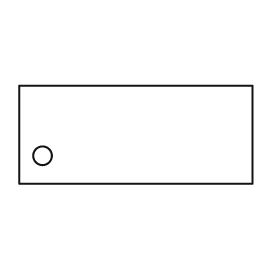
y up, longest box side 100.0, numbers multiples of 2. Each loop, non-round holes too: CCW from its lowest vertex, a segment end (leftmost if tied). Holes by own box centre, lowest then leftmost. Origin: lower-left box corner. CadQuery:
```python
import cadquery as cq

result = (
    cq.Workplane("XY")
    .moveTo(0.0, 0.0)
    .lineTo(100.0, 0.0)
    .lineTo(100.0, 42.0)
    .lineTo(0.0, 42.0)
    .close()
    .moveTo(10.0, 12.0)
    .circle(4.0)
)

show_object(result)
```